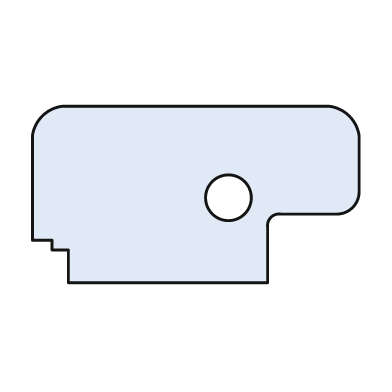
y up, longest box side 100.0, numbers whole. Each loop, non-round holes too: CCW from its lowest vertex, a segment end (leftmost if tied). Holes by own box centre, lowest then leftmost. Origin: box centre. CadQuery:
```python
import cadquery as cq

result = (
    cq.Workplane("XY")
    .moveTo(-39.0, -27.0)
    .lineTo(22.0, -27.0)
    .lineTo(22.0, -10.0)
    .threePointArc((23.0, -7.0), (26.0, -6.0))
    .lineTo(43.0, -6.0)
    .threePointArc((48.0, -4.0), (50.0, 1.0))
    .lineTo(50.0, 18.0)
    .threePointArc((47.0, 24.0), (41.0, 27.0))
    .lineTo(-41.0, 27.0)
    .threePointArc((-47.0, 24.0), (-50.0, 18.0))
    .lineTo(-50.0, -14.0)
    .lineTo(-44.0, -14.0)
    .lineTo(-44.0, -17.0)
    .lineTo(-39.0, -17.0)
    .close()
    .moveTo(10.0, -1.0)
    .circle(7.0)
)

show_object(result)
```